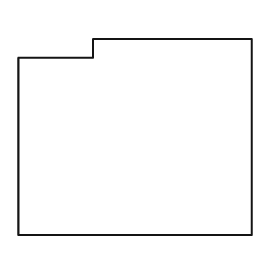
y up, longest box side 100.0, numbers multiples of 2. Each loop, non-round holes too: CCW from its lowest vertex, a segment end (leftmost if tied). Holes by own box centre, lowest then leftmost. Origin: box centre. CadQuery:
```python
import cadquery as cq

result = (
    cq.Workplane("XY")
    .moveTo(-50.0, -42.0)
    .lineTo(50.0, -42.0)
    .lineTo(50.0, 42.0)
    .lineTo(-18.0, 42.0)
    .lineTo(-18.0, 34.0)
    .lineTo(-50.0, 34.0)
    .close()
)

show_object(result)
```